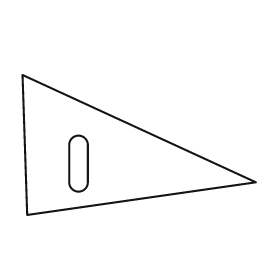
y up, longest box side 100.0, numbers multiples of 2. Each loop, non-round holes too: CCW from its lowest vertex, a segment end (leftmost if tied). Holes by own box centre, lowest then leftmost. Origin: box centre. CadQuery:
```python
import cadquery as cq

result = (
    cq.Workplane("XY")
    .moveTo(-48.0, -30.0)
    .lineTo(50.0, -16.0)
    .lineTo(-50.0, 30.0)
    .close()
    .moveTo(-30.0, -16.0)
    .threePointArc((-26.0, -20.0), (-22.0, -16.0))
    .lineTo(-22.0, 0.0)
    .threePointArc((-26.0, 4.0), (-30.0, 0.0))
    .close()
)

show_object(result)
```